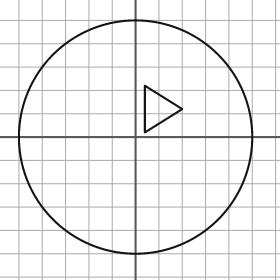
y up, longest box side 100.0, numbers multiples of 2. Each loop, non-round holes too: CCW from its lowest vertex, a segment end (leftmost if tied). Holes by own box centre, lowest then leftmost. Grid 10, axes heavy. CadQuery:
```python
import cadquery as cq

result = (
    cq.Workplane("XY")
    .moveTo(0.0, 0.0)
    .circle(50.0)
    .moveTo(4.0, 2.0)
    .lineTo(20.0, 12.0)
    .lineTo(4.0, 22.0)
    .close()
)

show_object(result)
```